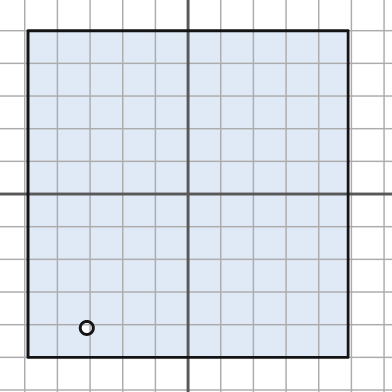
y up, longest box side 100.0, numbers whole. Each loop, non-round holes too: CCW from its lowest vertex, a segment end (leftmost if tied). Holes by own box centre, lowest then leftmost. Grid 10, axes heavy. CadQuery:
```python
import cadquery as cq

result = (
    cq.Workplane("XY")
    .moveTo(-49.0, -50.0)
    .lineTo(49.0, -50.0)
    .lineTo(49.0, 50.0)
    .lineTo(-49.0, 50.0)
    .close()
    .moveTo(-31.0, -41.0)
    .circle(2.0)
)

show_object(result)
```